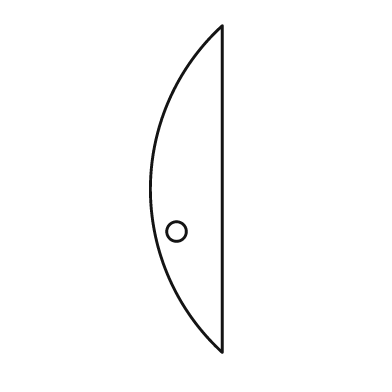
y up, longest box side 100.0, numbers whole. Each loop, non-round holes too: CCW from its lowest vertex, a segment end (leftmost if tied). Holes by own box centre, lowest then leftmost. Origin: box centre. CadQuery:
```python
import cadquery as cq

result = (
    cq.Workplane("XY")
    .moveTo(11.0, -50.0)
    .lineTo(11.0, 50.0)
    .threePointArc((-11.0, 0.0), (11.0, -50.0))
    .close()
    .moveTo(-3.0, -13.0)
    .circle(3.0)
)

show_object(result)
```